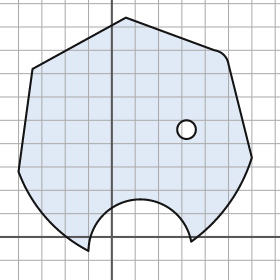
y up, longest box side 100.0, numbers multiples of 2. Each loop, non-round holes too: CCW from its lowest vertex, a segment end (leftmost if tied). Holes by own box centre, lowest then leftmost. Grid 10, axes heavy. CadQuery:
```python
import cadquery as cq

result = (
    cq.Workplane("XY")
    .moveTo(-10.0, -6.0)
    .threePointArc((10.0, 16.0), (34.0, -2.0))
    .threePointArc((50.0, 14.0), (60.0, 34.0))
    .lineTo(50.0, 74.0)
    .threePointArc((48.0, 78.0), (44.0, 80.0))
    .lineTo(6.0, 94.0)
    .lineTo(-34.0, 72.0)
    .lineTo(-40.0, 28.0)
    .threePointArc((-28.0, 8.0), (-10.0, -6.0))
    .close()
    .moveTo(32.0, 46.0)
    .circle(4.0)
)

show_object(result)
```